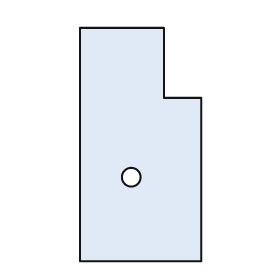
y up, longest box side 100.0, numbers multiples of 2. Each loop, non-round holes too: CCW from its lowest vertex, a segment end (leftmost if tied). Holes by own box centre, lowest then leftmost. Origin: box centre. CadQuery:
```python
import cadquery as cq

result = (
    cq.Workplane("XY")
    .moveTo(-26.0, -50.0)
    .lineTo(26.0, -50.0)
    .lineTo(26.0, 20.0)
    .lineTo(10.0, 20.0)
    .lineTo(10.0, 50.0)
    .lineTo(-26.0, 50.0)
    .close()
    .moveTo(-4.0, -14.0)
    .circle(4.0)
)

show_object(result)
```